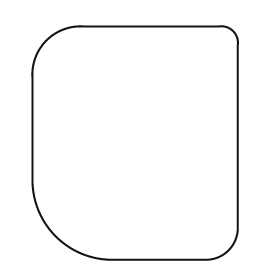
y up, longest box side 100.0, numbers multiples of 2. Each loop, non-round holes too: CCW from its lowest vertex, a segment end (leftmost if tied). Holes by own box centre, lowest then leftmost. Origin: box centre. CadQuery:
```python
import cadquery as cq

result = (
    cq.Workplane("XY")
    .moveTo(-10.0, -50.0)
    .lineTo(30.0, -50.0)
    .threePointArc((40.0, -46.0), (44.0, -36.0))
    .lineTo(44.0, 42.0)
    .threePointArc((42.0, 48.0), (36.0, 50.0))
    .lineTo(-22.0, 50.0)
    .threePointArc((-38.0, 44.0), (-44.0, 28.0))
    .lineTo(-44.0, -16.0)
    .threePointArc((-34.0, -40.0), (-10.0, -50.0))
    .close()
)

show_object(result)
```